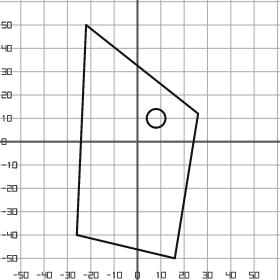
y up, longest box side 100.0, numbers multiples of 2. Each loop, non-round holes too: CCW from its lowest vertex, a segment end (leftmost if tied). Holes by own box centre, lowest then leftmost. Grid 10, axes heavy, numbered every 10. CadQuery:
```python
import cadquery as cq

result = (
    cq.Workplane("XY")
    .moveTo(16.0, -50.0)
    .lineTo(26.0, 12.0)
    .lineTo(-22.0, 50.0)
    .lineTo(-26.0, -40.0)
    .close()
    .moveTo(8.0, 10.0)
    .circle(4.0)
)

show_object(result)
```